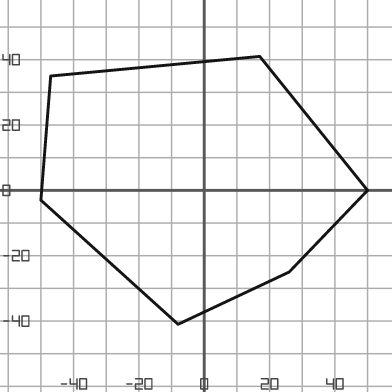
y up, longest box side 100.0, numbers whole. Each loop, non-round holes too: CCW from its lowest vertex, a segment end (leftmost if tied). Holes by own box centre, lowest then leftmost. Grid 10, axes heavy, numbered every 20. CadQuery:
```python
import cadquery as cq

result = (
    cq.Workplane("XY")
    .moveTo(-8.0, -41.0)
    .lineTo(26.0, -25.0)
    .lineTo(50.0, 0.0)
    .lineTo(17.0, 41.0)
    .lineTo(-47.0, 35.0)
    .lineTo(-50.0, -3.0)
    .close()
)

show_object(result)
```